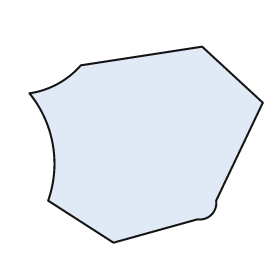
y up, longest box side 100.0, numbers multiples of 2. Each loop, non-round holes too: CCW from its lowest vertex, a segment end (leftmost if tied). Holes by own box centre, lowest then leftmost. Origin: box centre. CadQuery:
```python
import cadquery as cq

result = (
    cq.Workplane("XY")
    .moveTo(-14.0, -42.0)
    .lineTo(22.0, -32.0)
    .threePointArc((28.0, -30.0), (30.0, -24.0))
    .lineTo(50.0, 18.0)
    .lineTo(24.0, 42.0)
    .lineTo(-28.0, 34.0)
    .threePointArc((-38.0, 26.0), (-50.0, 22.0))
    .threePointArc((-40.0, 0.0), (-42.0, -24.0))
    .close()
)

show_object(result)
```